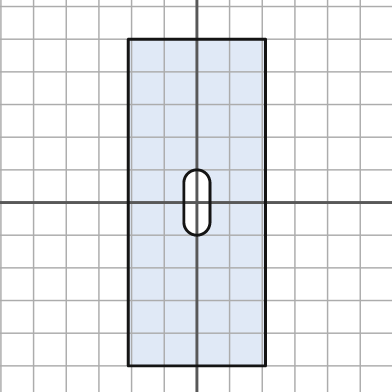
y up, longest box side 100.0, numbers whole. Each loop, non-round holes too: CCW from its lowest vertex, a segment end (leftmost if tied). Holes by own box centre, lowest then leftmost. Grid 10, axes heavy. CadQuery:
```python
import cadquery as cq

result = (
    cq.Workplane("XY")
    .moveTo(-21.0, -50.0)
    .lineTo(21.0, -50.0)
    .lineTo(21.0, 50.0)
    .lineTo(-21.0, 50.0)
    .close()
    .moveTo(-4.0, -6.0)
    .threePointArc((0.0, -10.0), (4.0, -6.0))
    .lineTo(4.0, 6.0)
    .threePointArc((0.0, 10.0), (-4.0, 6.0))
    .close()
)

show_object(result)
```